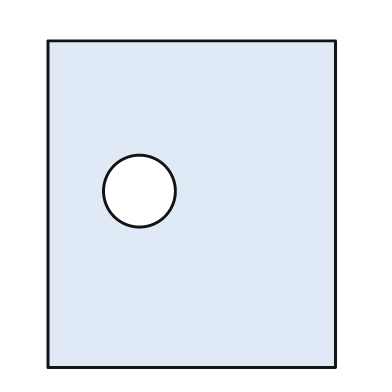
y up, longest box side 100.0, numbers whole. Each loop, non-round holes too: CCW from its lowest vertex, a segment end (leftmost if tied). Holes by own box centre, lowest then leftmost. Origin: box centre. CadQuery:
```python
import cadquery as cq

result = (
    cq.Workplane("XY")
    .moveTo(-44.0, -50.0)
    .lineTo(44.0, -50.0)
    .lineTo(44.0, 50.0)
    .lineTo(-44.0, 50.0)
    .close()
    .moveTo(-16.0, 4.0)
    .circle(11.0)
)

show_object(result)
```